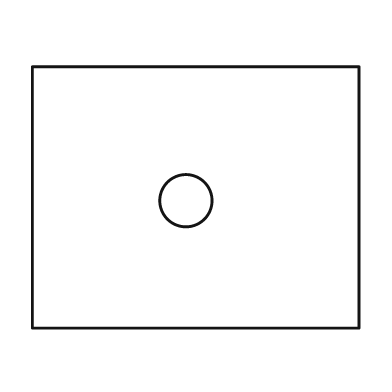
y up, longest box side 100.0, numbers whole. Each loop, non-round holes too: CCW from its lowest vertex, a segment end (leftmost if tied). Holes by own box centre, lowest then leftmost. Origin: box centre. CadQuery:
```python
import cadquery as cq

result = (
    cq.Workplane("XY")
    .moveTo(-50.0, -40.0)
    .lineTo(50.0, -40.0)
    .lineTo(50.0, 40.0)
    .lineTo(-50.0, 40.0)
    .close()
    .moveTo(-3.0, -1.0)
    .circle(8.0)
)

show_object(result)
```